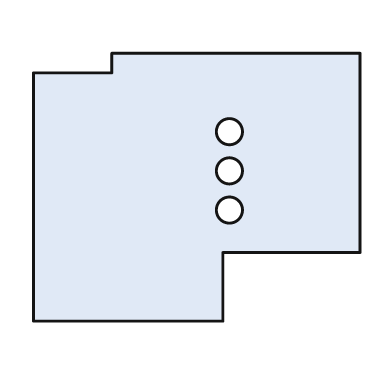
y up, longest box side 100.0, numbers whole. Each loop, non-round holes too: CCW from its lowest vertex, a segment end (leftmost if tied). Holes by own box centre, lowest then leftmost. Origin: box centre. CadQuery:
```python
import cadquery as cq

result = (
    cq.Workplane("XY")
    .moveTo(-50.0, -41.0)
    .lineTo(8.0, -41.0)
    .lineTo(8.0, -20.0)
    .lineTo(50.0, -20.0)
    .lineTo(50.0, 41.0)
    .lineTo(-26.0, 41.0)
    .lineTo(-26.0, 35.0)
    .lineTo(-50.0, 35.0)
    .close()
    .moveTo(10.0, -7.0)
    .circle(4.0)
    .moveTo(10.0, 5.0)
    .circle(4.0)
    .moveTo(10.0, 17.0)
    .circle(4.0)
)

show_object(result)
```